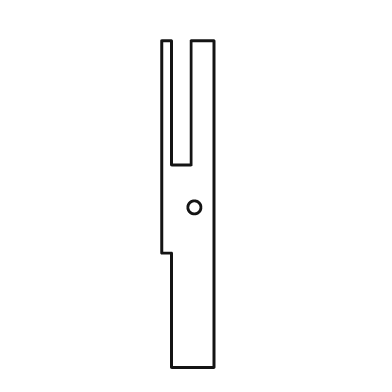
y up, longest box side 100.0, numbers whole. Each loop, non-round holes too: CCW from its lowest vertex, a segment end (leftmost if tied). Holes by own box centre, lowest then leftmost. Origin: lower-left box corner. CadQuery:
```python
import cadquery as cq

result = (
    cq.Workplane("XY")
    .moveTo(3.0, 0.0)
    .lineTo(16.0, 0.0)
    .lineTo(16.0, 100.0)
    .lineTo(9.0, 100.0)
    .lineTo(9.0, 62.0)
    .lineTo(3.0, 62.0)
    .lineTo(3.0, 100.0)
    .lineTo(0.0, 100.0)
    .lineTo(0.0, 35.0)
    .lineTo(3.0, 35.0)
    .close()
    .moveTo(10.0, 49.0)
    .circle(2.0)
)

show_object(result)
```